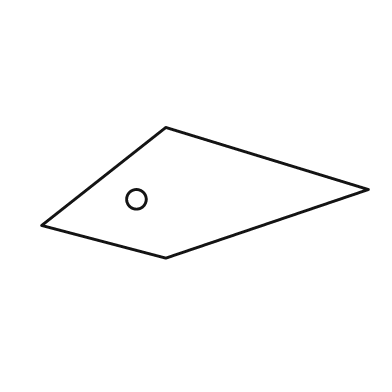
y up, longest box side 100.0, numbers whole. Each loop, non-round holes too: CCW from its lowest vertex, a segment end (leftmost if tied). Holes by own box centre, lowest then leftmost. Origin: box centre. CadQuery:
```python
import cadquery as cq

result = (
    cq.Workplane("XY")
    .moveTo(-12.0, -20.0)
    .lineTo(50.0, 1.0)
    .lineTo(-12.0, 20.0)
    .lineTo(-50.0, -10.0)
    .close()
    .moveTo(-21.0, -2.0)
    .circle(3.0)
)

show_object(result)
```